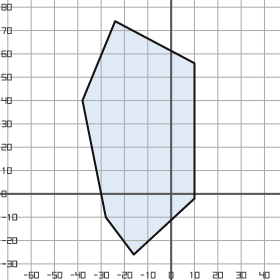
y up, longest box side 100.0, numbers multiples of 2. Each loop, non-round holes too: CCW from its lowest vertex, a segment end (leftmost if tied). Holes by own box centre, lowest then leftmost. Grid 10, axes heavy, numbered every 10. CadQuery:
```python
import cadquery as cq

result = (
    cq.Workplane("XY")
    .moveTo(-16.0, -26.0)
    .lineTo(10.0, -2.0)
    .lineTo(10.0, 56.0)
    .lineTo(-24.0, 74.0)
    .lineTo(-38.0, 40.0)
    .lineTo(-28.0, -10.0)
    .close()
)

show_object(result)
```